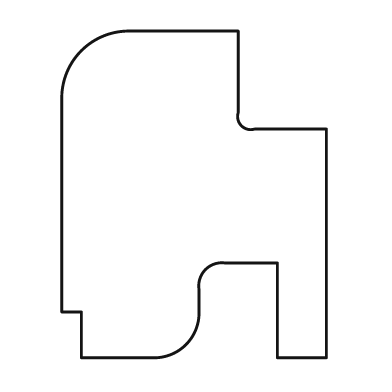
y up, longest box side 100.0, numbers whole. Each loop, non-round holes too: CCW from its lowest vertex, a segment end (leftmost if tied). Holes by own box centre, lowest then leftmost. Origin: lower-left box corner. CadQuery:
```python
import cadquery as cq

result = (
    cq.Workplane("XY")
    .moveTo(6.0, 0.0)
    .lineTo(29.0, 0.0)
    .threePointArc((38.0, 4.0), (42.0, 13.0))
    .lineTo(42.0, 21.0)
    .threePointArc((44.0, 27.0), (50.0, 29.0))
    .lineTo(66.0, 29.0)
    .lineTo(66.0, 0.0)
    .lineTo(81.0, 0.0)
    .lineTo(81.0, 70.0)
    .lineTo(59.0, 70.0)
    .threePointArc((55.0, 71.0), (54.0, 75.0))
    .lineTo(54.0, 100.0)
    .lineTo(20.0, 100.0)
    .threePointArc((6.0, 94.0), (0.0, 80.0))
    .lineTo(0.0, 14.0)
    .lineTo(6.0, 14.0)
    .close()
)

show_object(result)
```